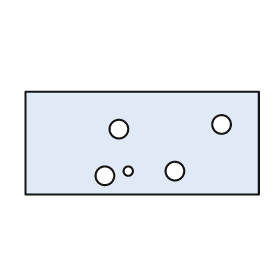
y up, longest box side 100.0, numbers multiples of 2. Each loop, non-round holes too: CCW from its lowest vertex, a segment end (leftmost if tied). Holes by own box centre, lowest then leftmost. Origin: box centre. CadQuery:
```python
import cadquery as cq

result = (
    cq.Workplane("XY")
    .moveTo(-50.0, -22.0)
    .lineTo(50.0, -22.0)
    .lineTo(50.0, 22.0)
    .lineTo(-50.0, 22.0)
    .close()
    .moveTo(-16.0, -14.0)
    .circle(4.0)
    .moveTo(-6.0, -12.0)
    .circle(2.0)
    .moveTo(14.0, -12.0)
    .circle(4.0)
    .moveTo(-10.0, 6.0)
    .circle(4.0)
    .moveTo(34.0, 8.0)
    .circle(4.0)
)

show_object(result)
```